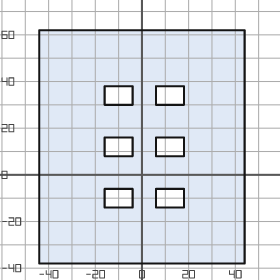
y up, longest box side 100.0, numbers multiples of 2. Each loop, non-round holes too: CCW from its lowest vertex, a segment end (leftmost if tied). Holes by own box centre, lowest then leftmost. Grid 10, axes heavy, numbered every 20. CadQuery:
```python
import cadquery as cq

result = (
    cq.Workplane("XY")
    .moveTo(-44.0, -38.0)
    .lineTo(44.0, -38.0)
    .lineTo(44.0, 62.0)
    .lineTo(-44.0, 62.0)
    .close()
    .moveTo(-16.0, -14.0)
    .lineTo(-4.0, -14.0)
    .lineTo(-4.0, -6.0)
    .lineTo(-16.0, -6.0)
    .close()
    .moveTo(6.0, -14.0)
    .lineTo(18.0, -14.0)
    .lineTo(18.0, -6.0)
    .lineTo(6.0, -6.0)
    .close()
    .moveTo(-16.0, 8.0)
    .lineTo(-4.0, 8.0)
    .lineTo(-4.0, 16.0)
    .lineTo(-16.0, 16.0)
    .close()
    .moveTo(6.0, 8.0)
    .lineTo(18.0, 8.0)
    .lineTo(18.0, 16.0)
    .lineTo(6.0, 16.0)
    .close()
    .moveTo(-16.0, 30.0)
    .lineTo(-4.0, 30.0)
    .lineTo(-4.0, 38.0)
    .lineTo(-16.0, 38.0)
    .close()
    .moveTo(6.0, 30.0)
    .lineTo(18.0, 30.0)
    .lineTo(18.0, 38.0)
    .lineTo(6.0, 38.0)
    .close()
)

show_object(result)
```